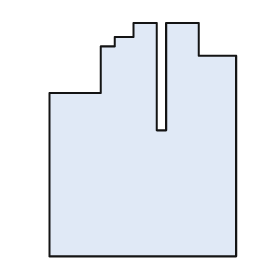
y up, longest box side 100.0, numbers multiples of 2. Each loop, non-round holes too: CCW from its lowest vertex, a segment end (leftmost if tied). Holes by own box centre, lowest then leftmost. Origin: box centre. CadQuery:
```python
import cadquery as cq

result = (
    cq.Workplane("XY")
    .moveTo(-40.0, -50.0)
    .lineTo(40.0, -50.0)
    .lineTo(40.0, 36.0)
    .lineTo(24.0, 36.0)
    .lineTo(24.0, 50.0)
    .lineTo(10.0, 50.0)
    .lineTo(10.0, 4.0)
    .lineTo(6.0, 4.0)
    .lineTo(6.0, 50.0)
    .lineTo(-4.0, 50.0)
    .lineTo(-4.0, 44.0)
    .lineTo(-12.0, 44.0)
    .lineTo(-12.0, 40.0)
    .lineTo(-18.0, 40.0)
    .lineTo(-18.0, 20.0)
    .lineTo(-40.0, 20.0)
    .close()
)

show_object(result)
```